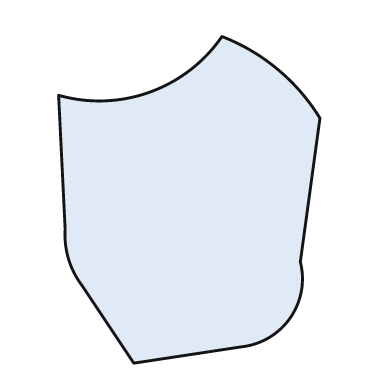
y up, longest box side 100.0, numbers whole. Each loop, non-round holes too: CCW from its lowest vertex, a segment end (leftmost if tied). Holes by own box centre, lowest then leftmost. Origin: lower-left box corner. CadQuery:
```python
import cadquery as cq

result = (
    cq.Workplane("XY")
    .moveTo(23.0, 0.0)
    .lineTo(56.0, 5.0)
    .threePointArc((71.0, 14.0), (74.0, 31.0))
    .lineTo(80.0, 75.0)
    .threePointArc((67.0, 90.0), (50.0, 100.0))
    .threePointArc((28.0, 83.0), (0.0, 82.0))
    .lineTo(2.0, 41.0)
    .threePointArc((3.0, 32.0), (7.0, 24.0))
    .close()
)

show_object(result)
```